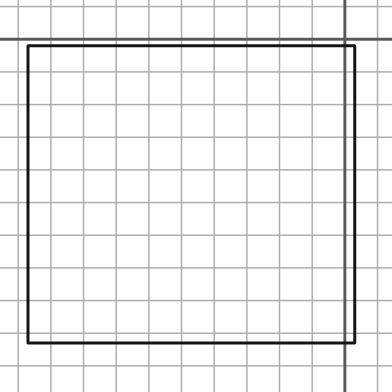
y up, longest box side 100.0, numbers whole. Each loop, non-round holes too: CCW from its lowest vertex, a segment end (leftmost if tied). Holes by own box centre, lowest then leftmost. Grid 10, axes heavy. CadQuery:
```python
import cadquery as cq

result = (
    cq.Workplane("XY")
    .moveTo(-97.0, -93.0)
    .lineTo(3.0, -93.0)
    .lineTo(3.0, -2.0)
    .lineTo(-97.0, -2.0)
    .close()
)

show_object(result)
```